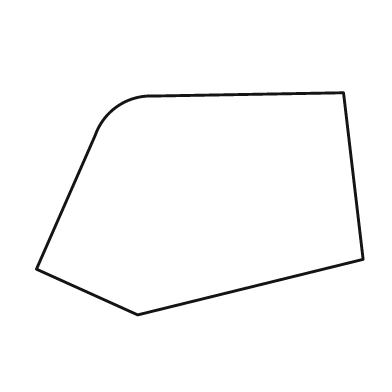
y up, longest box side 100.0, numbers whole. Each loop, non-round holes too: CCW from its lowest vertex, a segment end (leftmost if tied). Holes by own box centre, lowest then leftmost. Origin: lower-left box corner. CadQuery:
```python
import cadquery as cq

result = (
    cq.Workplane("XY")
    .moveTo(31.0, 0.0)
    .lineTo(100.0, 17.0)
    .lineTo(94.0, 68.0)
    .lineTo(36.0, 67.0)
    .threePointArc((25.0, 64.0), (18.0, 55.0))
    .lineTo(0.0, 14.0)
    .close()
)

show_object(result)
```